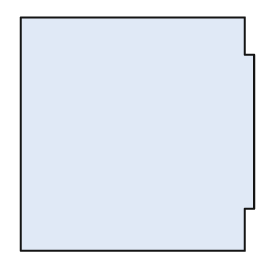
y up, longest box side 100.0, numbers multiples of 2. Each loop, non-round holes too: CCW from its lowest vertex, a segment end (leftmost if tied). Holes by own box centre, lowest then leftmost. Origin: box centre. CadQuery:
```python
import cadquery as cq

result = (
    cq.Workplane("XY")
    .moveTo(-50.0, -50.0)
    .lineTo(46.0, -50.0)
    .lineTo(46.0, -32.0)
    .lineTo(50.0, -32.0)
    .lineTo(50.0, 34.0)
    .lineTo(46.0, 34.0)
    .lineTo(46.0, 50.0)
    .lineTo(-50.0, 50.0)
    .close()
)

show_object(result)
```